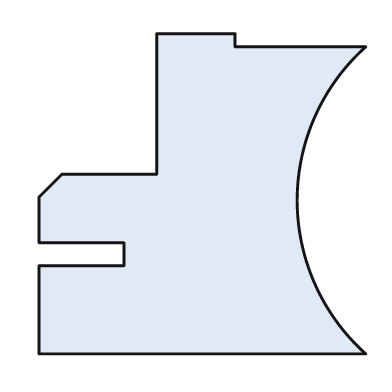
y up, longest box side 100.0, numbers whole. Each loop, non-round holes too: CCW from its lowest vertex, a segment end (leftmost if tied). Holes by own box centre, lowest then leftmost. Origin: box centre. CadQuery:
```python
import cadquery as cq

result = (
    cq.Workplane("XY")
    .moveTo(-50.0, -49.0)
    .lineTo(50.0, -49.0)
    .threePointArc((29.0, -2.0), (50.0, 45.0))
    .lineTo(10.0, 45.0)
    .lineTo(10.0, 49.0)
    .lineTo(-14.0, 49.0)
    .lineTo(-14.0, 6.0)
    .lineTo(-43.0, 6.0)
    .lineTo(-50.0, -1.0)
    .lineTo(-50.0, -15.0)
    .lineTo(-24.0, -15.0)
    .lineTo(-24.0, -22.0)
    .lineTo(-50.0, -22.0)
    .close()
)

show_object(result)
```